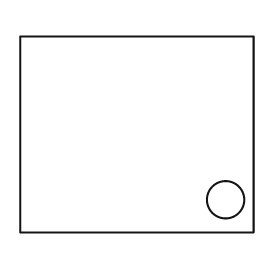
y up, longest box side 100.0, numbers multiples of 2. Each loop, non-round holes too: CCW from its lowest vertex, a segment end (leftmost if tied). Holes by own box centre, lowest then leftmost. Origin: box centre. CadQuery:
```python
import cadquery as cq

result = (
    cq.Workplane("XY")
    .moveTo(-50.0, -42.0)
    .lineTo(50.0, -42.0)
    .lineTo(50.0, 42.0)
    .lineTo(-50.0, 42.0)
    .close()
    .moveTo(38.0, -28.0)
    .circle(8.0)
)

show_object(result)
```